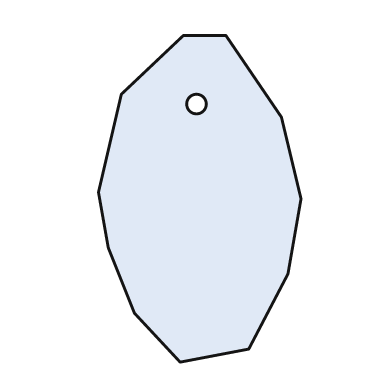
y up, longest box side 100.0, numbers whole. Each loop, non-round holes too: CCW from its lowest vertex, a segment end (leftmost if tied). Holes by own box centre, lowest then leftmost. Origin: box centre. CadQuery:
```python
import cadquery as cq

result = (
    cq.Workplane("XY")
    .moveTo(-6.0, -50.0)
    .lineTo(15.0, -46.0)
    .lineTo(27.0, -23.0)
    .lineTo(31.0, 0.0)
    .lineTo(25.0, 25.0)
    .lineTo(8.0, 50.0)
    .lineTo(-5.0, 50.0)
    .lineTo(-24.0, 32.0)
    .lineTo(-31.0, 2.0)
    .lineTo(-28.0, -15.0)
    .lineTo(-20.0, -35.0)
    .close()
    .moveTo(-1.0, 29.0)
    .circle(3.0)
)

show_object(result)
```